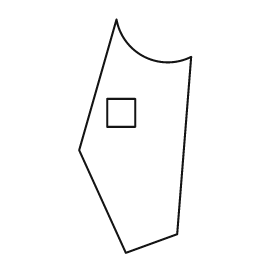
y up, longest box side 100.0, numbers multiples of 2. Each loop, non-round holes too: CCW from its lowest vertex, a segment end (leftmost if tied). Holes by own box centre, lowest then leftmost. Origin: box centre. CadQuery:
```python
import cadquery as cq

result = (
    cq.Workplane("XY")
    .moveTo(-4.0, -50.0)
    .lineTo(18.0, -42.0)
    .lineTo(24.0, 34.0)
    .threePointArc((4.0, 34.0), (-8.0, 50.0))
    .lineTo(-24.0, -6.0)
    .close()
    .moveTo(-12.0, 4.0)
    .lineTo(0.0, 4.0)
    .lineTo(0.0, 16.0)
    .lineTo(-12.0, 16.0)
    .close()
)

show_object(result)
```